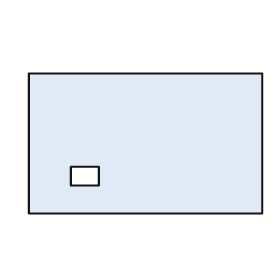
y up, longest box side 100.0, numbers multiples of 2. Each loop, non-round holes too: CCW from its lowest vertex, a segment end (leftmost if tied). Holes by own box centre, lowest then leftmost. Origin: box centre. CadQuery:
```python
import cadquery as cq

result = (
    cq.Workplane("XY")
    .moveTo(-50.0, -30.0)
    .lineTo(50.0, -30.0)
    .lineTo(50.0, 30.0)
    .lineTo(-50.0, 30.0)
    .close()
    .moveTo(-32.0, -18.0)
    .lineTo(-20.0, -18.0)
    .lineTo(-20.0, -10.0)
    .lineTo(-32.0, -10.0)
    .close()
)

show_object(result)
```